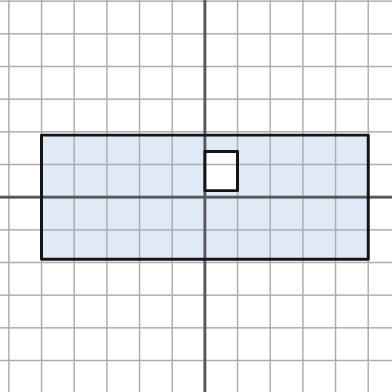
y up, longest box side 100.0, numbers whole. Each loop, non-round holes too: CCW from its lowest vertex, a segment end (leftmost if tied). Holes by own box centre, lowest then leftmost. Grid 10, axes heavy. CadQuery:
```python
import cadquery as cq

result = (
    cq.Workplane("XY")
    .moveTo(-50.0, -19.0)
    .lineTo(50.0, -19.0)
    .lineTo(50.0, 19.0)
    .lineTo(-50.0, 19.0)
    .close()
    .moveTo(0.0, 2.0)
    .lineTo(10.0, 2.0)
    .lineTo(10.0, 14.0)
    .lineTo(0.0, 14.0)
    .close()
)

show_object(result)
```